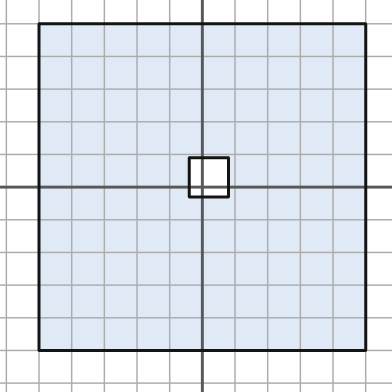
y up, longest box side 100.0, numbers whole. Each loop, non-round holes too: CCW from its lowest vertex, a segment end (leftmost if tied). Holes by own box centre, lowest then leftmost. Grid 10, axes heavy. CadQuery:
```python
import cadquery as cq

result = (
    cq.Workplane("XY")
    .moveTo(-50.0, -50.0)
    .lineTo(50.0, -50.0)
    .lineTo(50.0, 50.0)
    .lineTo(-50.0, 50.0)
    .close()
    .moveTo(-4.0, -3.0)
    .lineTo(8.0, -3.0)
    .lineTo(8.0, 9.0)
    .lineTo(-4.0, 9.0)
    .close()
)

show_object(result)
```